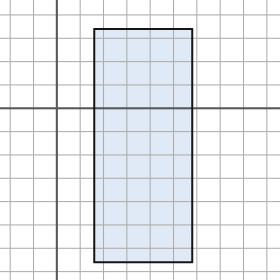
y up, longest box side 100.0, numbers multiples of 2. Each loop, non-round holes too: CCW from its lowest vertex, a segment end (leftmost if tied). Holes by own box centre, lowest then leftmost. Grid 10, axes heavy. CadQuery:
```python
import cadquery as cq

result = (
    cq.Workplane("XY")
    .moveTo(16.0, -66.0)
    .lineTo(58.0, -66.0)
    .lineTo(58.0, 34.0)
    .lineTo(16.0, 34.0)
    .close()
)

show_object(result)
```